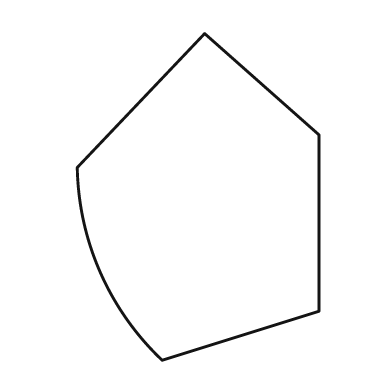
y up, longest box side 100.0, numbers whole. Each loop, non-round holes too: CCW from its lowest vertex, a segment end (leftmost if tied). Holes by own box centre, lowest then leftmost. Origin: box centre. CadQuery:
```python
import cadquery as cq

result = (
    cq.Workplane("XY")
    .moveTo(-11.0, -50.0)
    .lineTo(37.0, -35.0)
    .lineTo(37.0, 19.0)
    .lineTo(2.0, 50.0)
    .lineTo(-37.0, 9.0)
    .threePointArc((-30.0, -23.0), (-11.0, -50.0))
    .close()
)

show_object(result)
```